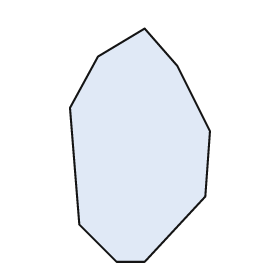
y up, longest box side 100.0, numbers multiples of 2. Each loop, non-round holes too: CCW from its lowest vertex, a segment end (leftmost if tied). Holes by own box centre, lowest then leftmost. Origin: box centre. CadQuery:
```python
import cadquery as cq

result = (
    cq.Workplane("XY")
    .moveTo(-10.0, -50.0)
    .lineTo(2.0, -50.0)
    .lineTo(28.0, -22.0)
    .lineTo(30.0, 6.0)
    .lineTo(16.0, 34.0)
    .lineTo(2.0, 50.0)
    .lineTo(-18.0, 38.0)
    .lineTo(-30.0, 16.0)
    .lineTo(-26.0, -34.0)
    .close()
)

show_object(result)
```